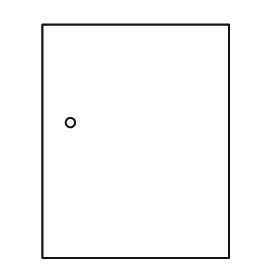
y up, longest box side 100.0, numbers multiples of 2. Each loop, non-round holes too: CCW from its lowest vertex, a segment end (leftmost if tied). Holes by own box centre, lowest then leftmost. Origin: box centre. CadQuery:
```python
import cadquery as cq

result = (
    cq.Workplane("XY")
    .moveTo(-40.0, -50.0)
    .lineTo(40.0, -50.0)
    .lineTo(40.0, 50.0)
    .lineTo(-40.0, 50.0)
    .close()
    .moveTo(-28.0, 8.0)
    .circle(2.0)
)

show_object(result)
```